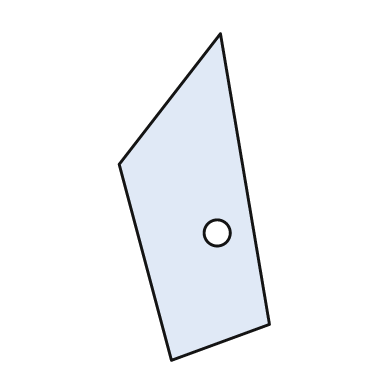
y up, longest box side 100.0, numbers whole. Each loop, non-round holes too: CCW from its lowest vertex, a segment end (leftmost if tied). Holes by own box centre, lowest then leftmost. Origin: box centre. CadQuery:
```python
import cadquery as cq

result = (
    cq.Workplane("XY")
    .moveTo(-7.0, -50.0)
    .lineTo(23.0, -39.0)
    .lineTo(8.0, 50.0)
    .lineTo(-23.0, 10.0)
    .close()
    .moveTo(7.0, -11.0)
    .circle(4.0)
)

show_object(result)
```